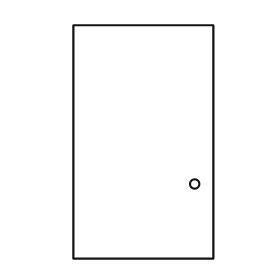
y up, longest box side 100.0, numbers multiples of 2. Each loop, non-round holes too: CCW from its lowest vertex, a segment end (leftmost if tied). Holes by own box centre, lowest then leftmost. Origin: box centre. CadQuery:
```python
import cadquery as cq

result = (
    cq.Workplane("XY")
    .moveTo(-30.0, -50.0)
    .lineTo(30.0, -50.0)
    .lineTo(30.0, 50.0)
    .lineTo(-30.0, 50.0)
    .close()
    .moveTo(22.0, -18.0)
    .circle(2.0)
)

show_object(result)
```